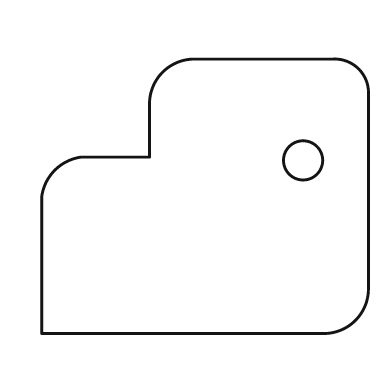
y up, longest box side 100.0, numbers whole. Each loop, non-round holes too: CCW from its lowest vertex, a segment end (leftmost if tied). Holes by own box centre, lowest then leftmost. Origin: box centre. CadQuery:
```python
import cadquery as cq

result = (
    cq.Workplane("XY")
    .moveTo(-50.0, -42.0)
    .lineTo(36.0, -42.0)
    .threePointArc((46.0, -38.0), (50.0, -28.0))
    .lineTo(50.0, 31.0)
    .threePointArc((47.0, 39.0), (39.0, 42.0))
    .lineTo(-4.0, 42.0)
    .threePointArc((-13.0, 38.0), (-17.0, 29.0))
    .lineTo(-17.0, 12.0)
    .lineTo(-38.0, 12.0)
    .threePointArc((-46.0, 8.0), (-50.0, 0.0))
    .close()
    .moveTo(30.0, 11.0)
    .circle(6.0)
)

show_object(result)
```